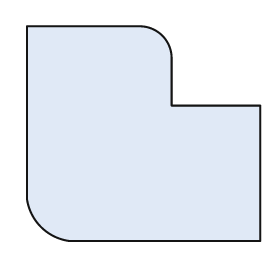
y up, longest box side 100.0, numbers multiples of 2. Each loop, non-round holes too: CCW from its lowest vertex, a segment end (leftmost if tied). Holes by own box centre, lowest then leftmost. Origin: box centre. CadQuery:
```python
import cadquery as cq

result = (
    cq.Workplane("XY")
    .moveTo(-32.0, -46.0)
    .lineTo(50.0, -46.0)
    .lineTo(50.0, 12.0)
    .lineTo(12.0, 12.0)
    .lineTo(12.0, 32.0)
    .threePointArc((8.0, 42.0), (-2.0, 46.0))
    .lineTo(-50.0, 46.0)
    .lineTo(-50.0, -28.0)
    .threePointArc((-44.0, -40.0), (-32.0, -46.0))
    .close()
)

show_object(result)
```